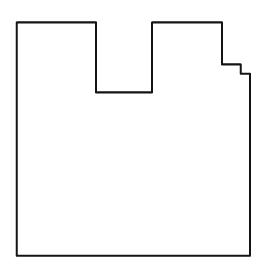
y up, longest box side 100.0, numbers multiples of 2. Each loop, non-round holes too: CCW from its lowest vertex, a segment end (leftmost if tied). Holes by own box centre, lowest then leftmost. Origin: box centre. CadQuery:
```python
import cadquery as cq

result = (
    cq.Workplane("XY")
    .moveTo(-50.0, -50.0)
    .lineTo(50.0, -50.0)
    .lineTo(50.0, 28.0)
    .lineTo(46.0, 28.0)
    .lineTo(46.0, 32.0)
    .lineTo(38.0, 32.0)
    .lineTo(38.0, 50.0)
    .lineTo(8.0, 50.0)
    .lineTo(8.0, 20.0)
    .lineTo(-16.0, 20.0)
    .lineTo(-16.0, 50.0)
    .lineTo(-50.0, 50.0)
    .close()
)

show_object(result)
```